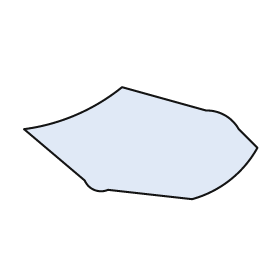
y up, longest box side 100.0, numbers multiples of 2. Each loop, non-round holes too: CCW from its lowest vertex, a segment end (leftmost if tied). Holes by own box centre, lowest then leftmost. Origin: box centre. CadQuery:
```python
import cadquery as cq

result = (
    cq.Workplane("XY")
    .moveTo(22.0, -24.0)
    .threePointArc((38.0, -16.0), (50.0, -2.0))
    .lineTo(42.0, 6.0)
    .threePointArc((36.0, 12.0), (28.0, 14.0))
    .lineTo(-8.0, 24.0)
    .threePointArc((-28.0, 12.0), (-50.0, 6.0))
    .lineTo(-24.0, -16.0)
    .threePointArc((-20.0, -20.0), (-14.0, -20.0))
    .close()
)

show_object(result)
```